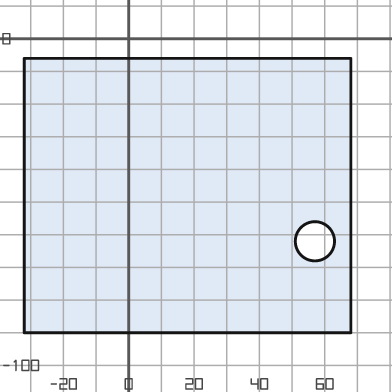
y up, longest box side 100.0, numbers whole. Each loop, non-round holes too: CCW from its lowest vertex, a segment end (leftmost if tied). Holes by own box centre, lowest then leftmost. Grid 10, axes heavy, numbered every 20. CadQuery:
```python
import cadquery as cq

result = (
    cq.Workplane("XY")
    .moveTo(-32.0, -90.0)
    .lineTo(68.0, -90.0)
    .lineTo(68.0, -6.0)
    .lineTo(-32.0, -6.0)
    .close()
    .moveTo(57.0, -62.0)
    .circle(6.0)
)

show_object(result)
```